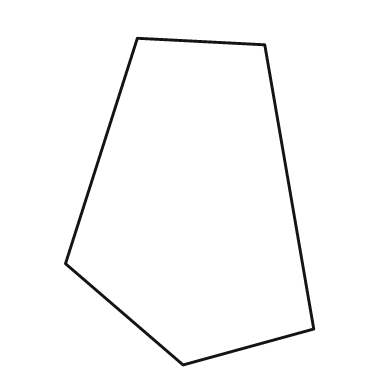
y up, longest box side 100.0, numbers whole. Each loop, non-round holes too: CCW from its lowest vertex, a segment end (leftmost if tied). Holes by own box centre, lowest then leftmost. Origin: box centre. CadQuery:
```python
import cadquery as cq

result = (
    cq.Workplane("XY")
    .moveTo(-2.0, -50.0)
    .lineTo(38.0, -39.0)
    .lineTo(23.0, 48.0)
    .lineTo(-16.0, 50.0)
    .lineTo(-38.0, -19.0)
    .close()
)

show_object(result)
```